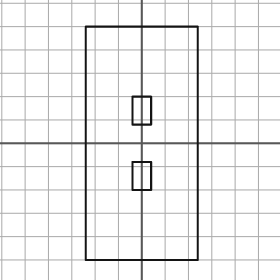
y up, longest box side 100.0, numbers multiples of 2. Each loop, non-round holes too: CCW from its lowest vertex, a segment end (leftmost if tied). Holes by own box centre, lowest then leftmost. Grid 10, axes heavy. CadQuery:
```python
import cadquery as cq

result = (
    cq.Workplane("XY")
    .moveTo(-24.0, -50.0)
    .lineTo(24.0, -50.0)
    .lineTo(24.0, 50.0)
    .lineTo(-24.0, 50.0)
    .close()
    .moveTo(-4.0, -20.0)
    .lineTo(4.0, -20.0)
    .lineTo(4.0, -8.0)
    .lineTo(-4.0, -8.0)
    .close()
    .moveTo(-4.0, 8.0)
    .lineTo(4.0, 8.0)
    .lineTo(4.0, 20.0)
    .lineTo(-4.0, 20.0)
    .close()
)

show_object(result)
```